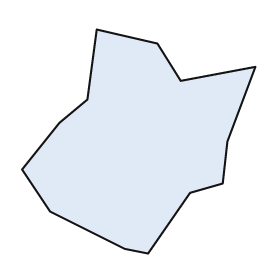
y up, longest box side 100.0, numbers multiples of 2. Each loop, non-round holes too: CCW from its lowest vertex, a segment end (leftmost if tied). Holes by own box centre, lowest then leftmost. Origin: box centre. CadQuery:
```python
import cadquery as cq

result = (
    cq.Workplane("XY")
    .moveTo(4.0, -48.0)
    .lineTo(22.0, -22.0)
    .lineTo(36.0, -18.0)
    .lineTo(38.0, 0.0)
    .lineTo(50.0, 32.0)
    .lineTo(18.0, 26.0)
    .lineTo(8.0, 42.0)
    .lineTo(-18.0, 48.0)
    .lineTo(-22.0, 18.0)
    .lineTo(-34.0, 8.0)
    .lineTo(-50.0, -12.0)
    .lineTo(-38.0, -30.0)
    .lineTo(-6.0, -46.0)
    .close()
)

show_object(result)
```